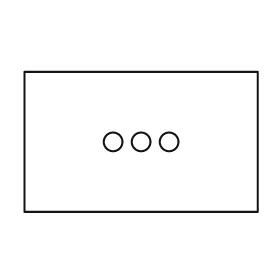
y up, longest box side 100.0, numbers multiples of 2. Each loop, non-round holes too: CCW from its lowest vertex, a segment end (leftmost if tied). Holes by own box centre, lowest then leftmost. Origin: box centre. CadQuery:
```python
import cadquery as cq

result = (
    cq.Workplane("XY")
    .moveTo(-50.0, -30.0)
    .lineTo(50.0, -30.0)
    .lineTo(50.0, 30.0)
    .lineTo(-50.0, 30.0)
    .close()
    .moveTo(-12.0, 0.0)
    .circle(4.0)
    .moveTo(0.0, 0.0)
    .circle(4.0)
    .moveTo(12.0, 0.0)
    .circle(4.0)
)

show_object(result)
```